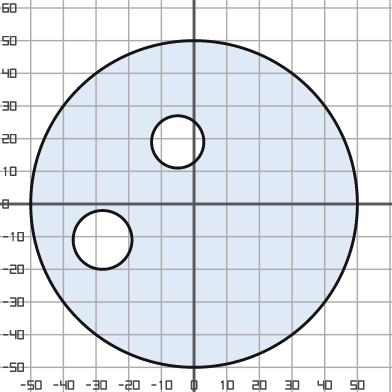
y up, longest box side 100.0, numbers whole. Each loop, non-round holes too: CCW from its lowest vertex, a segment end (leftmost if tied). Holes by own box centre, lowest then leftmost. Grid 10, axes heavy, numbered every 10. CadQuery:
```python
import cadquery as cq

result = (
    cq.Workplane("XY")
    .moveTo(0.0, 0.0)
    .circle(50.0)
    .moveTo(-28.0, -11.0)
    .circle(9.0)
    .moveTo(-5.0, 19.0)
    .circle(8.0)
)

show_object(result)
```